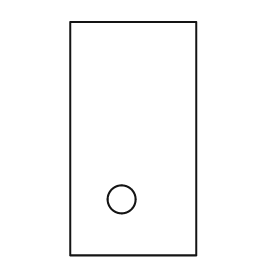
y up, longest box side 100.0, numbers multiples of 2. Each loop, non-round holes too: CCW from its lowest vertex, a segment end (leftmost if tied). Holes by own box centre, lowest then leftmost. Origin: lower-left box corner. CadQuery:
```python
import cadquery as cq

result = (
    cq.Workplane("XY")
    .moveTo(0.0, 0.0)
    .lineTo(54.0, 0.0)
    .lineTo(54.0, 100.0)
    .lineTo(0.0, 100.0)
    .close()
    .moveTo(22.0, 24.0)
    .circle(6.0)
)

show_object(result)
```